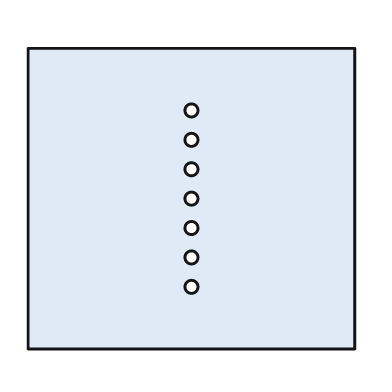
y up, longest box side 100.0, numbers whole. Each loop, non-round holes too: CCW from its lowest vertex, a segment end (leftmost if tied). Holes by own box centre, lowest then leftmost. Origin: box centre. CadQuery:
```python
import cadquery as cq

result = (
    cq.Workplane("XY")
    .moveTo(-50.0, -46.0)
    .lineTo(50.0, -46.0)
    .lineTo(50.0, 46.0)
    .lineTo(-50.0, 46.0)
    .close()
    .moveTo(0.0, -27.0)
    .circle(2.0)
    .moveTo(0.0, -18.0)
    .circle(2.0)
    .moveTo(0.0, -9.0)
    .circle(2.0)
    .moveTo(0.0, 0.0)
    .circle(2.0)
    .moveTo(0.0, 9.0)
    .circle(2.0)
    .moveTo(0.0, 18.0)
    .circle(2.0)
    .moveTo(0.0, 27.0)
    .circle(2.0)
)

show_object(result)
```